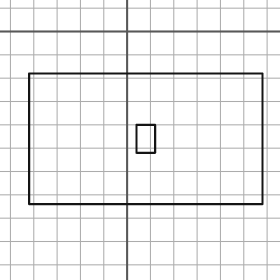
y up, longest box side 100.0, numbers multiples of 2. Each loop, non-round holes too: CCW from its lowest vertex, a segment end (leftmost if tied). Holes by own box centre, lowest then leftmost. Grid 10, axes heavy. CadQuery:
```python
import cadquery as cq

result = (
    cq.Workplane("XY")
    .moveTo(-42.0, -74.0)
    .lineTo(58.0, -74.0)
    .lineTo(58.0, -18.0)
    .lineTo(-42.0, -18.0)
    .close()
    .moveTo(4.0, -52.0)
    .lineTo(12.0, -52.0)
    .lineTo(12.0, -40.0)
    .lineTo(4.0, -40.0)
    .close()
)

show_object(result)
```